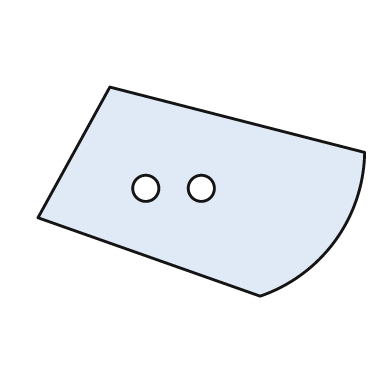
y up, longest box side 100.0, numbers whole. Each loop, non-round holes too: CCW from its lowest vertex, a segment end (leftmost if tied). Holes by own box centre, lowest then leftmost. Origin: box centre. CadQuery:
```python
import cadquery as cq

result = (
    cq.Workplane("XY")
    .moveTo(18.0, -32.0)
    .threePointArc((41.0, -15.0), (50.0, 12.0))
    .lineTo(-28.0, 32.0)
    .lineTo(-50.0, -8.0)
    .close()
    .moveTo(-17.0, 1.0)
    .circle(4.0)
    .moveTo(0.0, 1.0)
    .circle(4.0)
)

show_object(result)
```